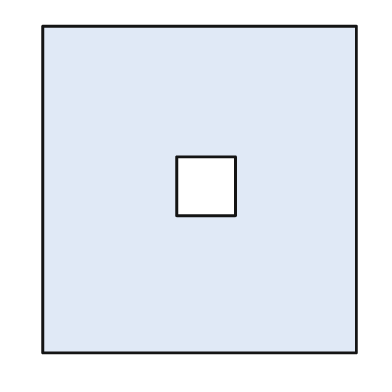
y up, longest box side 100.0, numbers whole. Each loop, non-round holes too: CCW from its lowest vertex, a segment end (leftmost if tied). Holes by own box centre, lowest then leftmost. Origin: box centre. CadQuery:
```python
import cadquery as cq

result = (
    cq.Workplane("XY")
    .moveTo(-48.0, -50.0)
    .lineTo(48.0, -50.0)
    .lineTo(48.0, 50.0)
    .lineTo(-48.0, 50.0)
    .close()
    .moveTo(-7.0, -8.0)
    .lineTo(11.0, -8.0)
    .lineTo(11.0, 10.0)
    .lineTo(-7.0, 10.0)
    .close()
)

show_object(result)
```